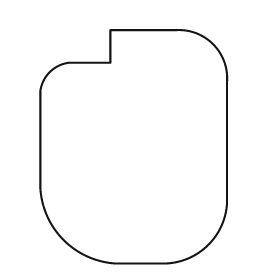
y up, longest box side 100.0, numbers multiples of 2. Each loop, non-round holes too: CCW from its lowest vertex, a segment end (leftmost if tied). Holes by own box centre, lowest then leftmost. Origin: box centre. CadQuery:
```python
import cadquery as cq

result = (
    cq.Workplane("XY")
    .moveTo(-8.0, -50.0)
    .lineTo(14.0, -50.0)
    .threePointArc((32.0, -42.0), (40.0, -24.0))
    .lineTo(40.0, 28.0)
    .threePointArc((34.0, 44.0), (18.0, 50.0))
    .lineTo(-10.0, 50.0)
    .lineTo(-10.0, 36.0)
    .lineTo(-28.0, 36.0)
    .threePointArc((-36.0, 32.0), (-40.0, 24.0))
    .lineTo(-40.0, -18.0)
    .threePointArc((-30.0, -40.0), (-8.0, -50.0))
    .close()
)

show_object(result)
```